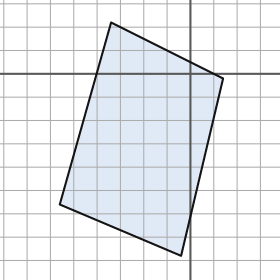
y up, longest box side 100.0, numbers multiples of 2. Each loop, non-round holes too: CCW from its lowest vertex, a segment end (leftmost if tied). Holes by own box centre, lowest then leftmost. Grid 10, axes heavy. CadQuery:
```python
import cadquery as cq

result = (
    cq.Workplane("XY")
    .moveTo(-4.0, -78.0)
    .lineTo(14.0, -2.0)
    .lineTo(-34.0, 22.0)
    .lineTo(-56.0, -56.0)
    .close()
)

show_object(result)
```